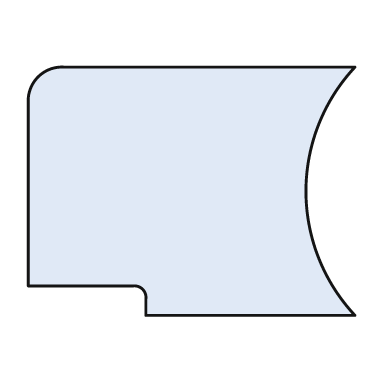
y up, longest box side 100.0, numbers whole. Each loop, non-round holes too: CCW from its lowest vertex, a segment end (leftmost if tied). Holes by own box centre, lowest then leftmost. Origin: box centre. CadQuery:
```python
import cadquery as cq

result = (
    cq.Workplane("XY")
    .moveTo(-14.0, -38.0)
    .lineTo(50.0, -38.0)
    .threePointArc((35.0, 0.0), (50.0, 38.0))
    .lineTo(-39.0, 38.0)
    .threePointArc((-47.0, 35.0), (-50.0, 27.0))
    .lineTo(-50.0, -29.0)
    .lineTo(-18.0, -29.0)
    .threePointArc((-15.0, -30.0), (-14.0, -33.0))
    .close()
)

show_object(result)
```